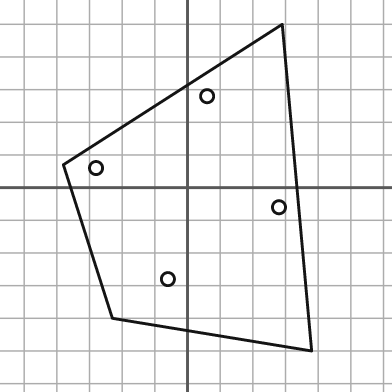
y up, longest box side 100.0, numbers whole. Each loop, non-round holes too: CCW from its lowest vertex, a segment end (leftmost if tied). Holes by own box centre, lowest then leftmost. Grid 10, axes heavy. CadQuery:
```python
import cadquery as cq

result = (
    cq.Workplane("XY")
    .moveTo(38.0, -50.0)
    .lineTo(29.0, 50.0)
    .lineTo(-38.0, 7.0)
    .lineTo(-23.0, -40.0)
    .close()
    .moveTo(-6.0, -28.0)
    .circle(2.0)
    .moveTo(28.0, -6.0)
    .circle(2.0)
    .moveTo(-28.0, 6.0)
    .circle(2.0)
    .moveTo(6.0, 28.0)
    .circle(2.0)
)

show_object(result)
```